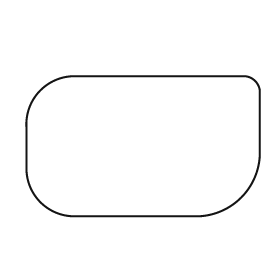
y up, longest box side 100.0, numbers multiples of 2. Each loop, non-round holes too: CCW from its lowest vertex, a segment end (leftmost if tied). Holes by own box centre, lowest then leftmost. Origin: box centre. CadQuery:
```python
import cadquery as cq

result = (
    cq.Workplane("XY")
    .moveTo(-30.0, -30.0)
    .lineTo(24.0, -30.0)
    .threePointArc((42.0, -22.0), (50.0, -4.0))
    .lineTo(50.0, 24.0)
    .threePointArc((48.0, 28.0), (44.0, 30.0))
    .lineTo(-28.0, 30.0)
    .threePointArc((-44.0, 24.0), (-50.0, 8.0))
    .lineTo(-50.0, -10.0)
    .threePointArc((-44.0, -24.0), (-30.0, -30.0))
    .close()
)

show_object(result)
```